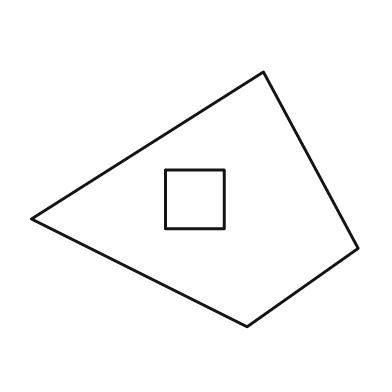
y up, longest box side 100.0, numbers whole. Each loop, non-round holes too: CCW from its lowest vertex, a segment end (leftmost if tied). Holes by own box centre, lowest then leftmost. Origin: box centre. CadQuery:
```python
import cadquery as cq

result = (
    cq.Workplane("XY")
    .moveTo(16.0, -39.0)
    .lineTo(50.0, -15.0)
    .lineTo(21.0, 39.0)
    .lineTo(-50.0, -6.0)
    .close()
    .moveTo(-9.0, -9.0)
    .lineTo(9.0, -9.0)
    .lineTo(9.0, 9.0)
    .lineTo(-9.0, 9.0)
    .close()
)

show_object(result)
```